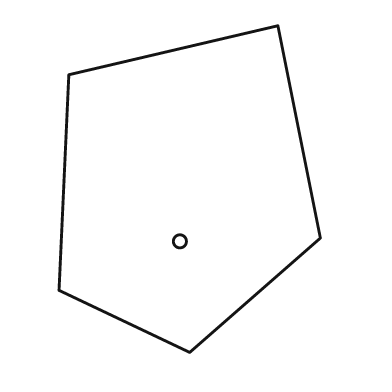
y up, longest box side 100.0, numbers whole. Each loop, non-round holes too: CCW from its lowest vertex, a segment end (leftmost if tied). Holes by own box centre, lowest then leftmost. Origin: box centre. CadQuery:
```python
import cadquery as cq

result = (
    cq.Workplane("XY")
    .moveTo(0.0, -50.0)
    .lineTo(40.0, -15.0)
    .lineTo(27.0, 50.0)
    .lineTo(-37.0, 35.0)
    .lineTo(-40.0, -31.0)
    .close()
    .moveTo(-3.0, -16.0)
    .circle(2.0)
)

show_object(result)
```